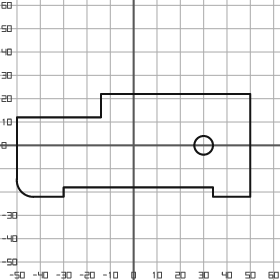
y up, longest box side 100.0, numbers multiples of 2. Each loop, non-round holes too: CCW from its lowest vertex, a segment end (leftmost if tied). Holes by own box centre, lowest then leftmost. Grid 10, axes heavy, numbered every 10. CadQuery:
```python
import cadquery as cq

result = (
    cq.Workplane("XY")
    .moveTo(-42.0, -22.0)
    .lineTo(-30.0, -22.0)
    .lineTo(-30.0, -18.0)
    .lineTo(34.0, -18.0)
    .lineTo(34.0, -22.0)
    .lineTo(50.0, -22.0)
    .lineTo(50.0, 22.0)
    .lineTo(-14.0, 22.0)
    .lineTo(-14.0, 12.0)
    .lineTo(-50.0, 12.0)
    .lineTo(-50.0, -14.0)
    .threePointArc((-48.0, -20.0), (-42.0, -22.0))
    .close()
    .moveTo(30.0, 0.0)
    .circle(4.0)
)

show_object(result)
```